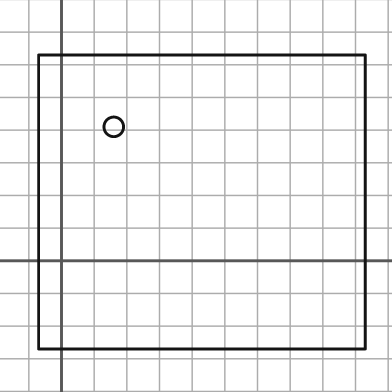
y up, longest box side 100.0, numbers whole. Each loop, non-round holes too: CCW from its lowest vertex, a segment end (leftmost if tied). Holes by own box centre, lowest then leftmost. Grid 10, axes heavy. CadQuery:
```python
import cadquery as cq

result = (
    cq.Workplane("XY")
    .moveTo(-7.0, -27.0)
    .lineTo(93.0, -27.0)
    .lineTo(93.0, 63.0)
    .lineTo(-7.0, 63.0)
    .close()
    .moveTo(16.0, 41.0)
    .circle(3.0)
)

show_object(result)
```